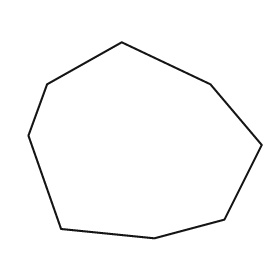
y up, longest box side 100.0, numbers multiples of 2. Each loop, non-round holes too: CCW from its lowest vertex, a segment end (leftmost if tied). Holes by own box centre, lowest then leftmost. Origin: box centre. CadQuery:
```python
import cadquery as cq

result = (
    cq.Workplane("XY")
    .moveTo(4.0, -42.0)
    .lineTo(34.0, -34.0)
    .lineTo(50.0, -2.0)
    .lineTo(28.0, 24.0)
    .lineTo(-10.0, 42.0)
    .lineTo(-42.0, 24.0)
    .lineTo(-50.0, 2.0)
    .lineTo(-36.0, -38.0)
    .close()
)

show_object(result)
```